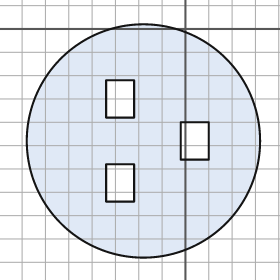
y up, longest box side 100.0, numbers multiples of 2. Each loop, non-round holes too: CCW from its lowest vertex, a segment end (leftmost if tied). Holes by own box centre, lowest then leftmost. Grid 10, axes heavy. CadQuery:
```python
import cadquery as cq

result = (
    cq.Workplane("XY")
    .moveTo(-18.0, -48.0)
    .circle(50.0)
    .moveTo(-34.0, -74.0)
    .lineTo(-22.0, -74.0)
    .lineTo(-22.0, -58.0)
    .lineTo(-34.0, -58.0)
    .close()
    .moveTo(-2.0, -56.0)
    .lineTo(10.0, -56.0)
    .lineTo(10.0, -40.0)
    .lineTo(-2.0, -40.0)
    .close()
    .moveTo(-34.0, -38.0)
    .lineTo(-22.0, -38.0)
    .lineTo(-22.0, -22.0)
    .lineTo(-34.0, -22.0)
    .close()
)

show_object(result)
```